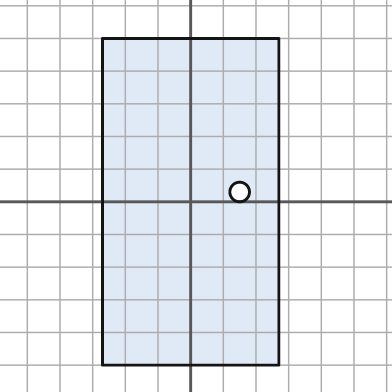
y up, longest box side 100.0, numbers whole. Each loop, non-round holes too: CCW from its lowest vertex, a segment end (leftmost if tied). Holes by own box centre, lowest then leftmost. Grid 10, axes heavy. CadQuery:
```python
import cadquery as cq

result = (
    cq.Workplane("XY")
    .moveTo(-27.0, -50.0)
    .lineTo(27.0, -50.0)
    .lineTo(27.0, 50.0)
    .lineTo(-27.0, 50.0)
    .close()
    .moveTo(15.0, 3.0)
    .circle(3.0)
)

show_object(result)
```